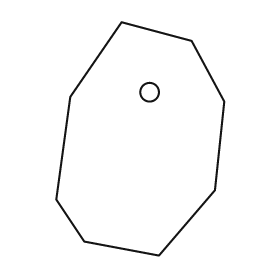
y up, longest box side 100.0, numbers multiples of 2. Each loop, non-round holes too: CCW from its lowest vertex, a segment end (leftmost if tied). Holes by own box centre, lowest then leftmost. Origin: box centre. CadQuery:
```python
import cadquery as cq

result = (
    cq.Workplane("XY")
    .moveTo(8.0, -50.0)
    .lineTo(32.0, -22.0)
    .lineTo(36.0, 16.0)
    .lineTo(22.0, 42.0)
    .lineTo(-8.0, 50.0)
    .lineTo(-30.0, 18.0)
    .lineTo(-36.0, -26.0)
    .lineTo(-24.0, -44.0)
    .close()
    .moveTo(4.0, 20.0)
    .circle(4.0)
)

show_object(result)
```